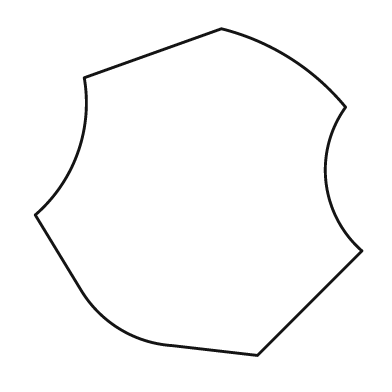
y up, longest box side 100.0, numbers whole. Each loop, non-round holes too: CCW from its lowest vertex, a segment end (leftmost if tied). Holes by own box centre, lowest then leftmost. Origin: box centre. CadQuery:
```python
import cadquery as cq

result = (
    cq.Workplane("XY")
    .moveTo(18.0, -50.0)
    .lineTo(50.0, -18.0)
    .threePointArc((39.0, 3.0), (45.0, 26.0))
    .threePointArc((28.0, 41.0), (7.0, 50.0))
    .lineTo(-35.0, 35.0)
    .threePointArc((-37.0, 12.0), (-50.0, -7.0))
    .lineTo(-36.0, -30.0)
    .threePointArc((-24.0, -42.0), (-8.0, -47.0))
    .close()
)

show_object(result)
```